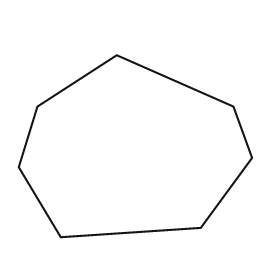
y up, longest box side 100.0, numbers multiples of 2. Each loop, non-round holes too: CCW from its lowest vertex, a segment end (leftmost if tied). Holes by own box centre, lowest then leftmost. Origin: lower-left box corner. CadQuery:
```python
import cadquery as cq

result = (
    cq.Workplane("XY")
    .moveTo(18.0, 0.0)
    .lineTo(78.0, 4.0)
    .lineTo(100.0, 34.0)
    .lineTo(92.0, 56.0)
    .lineTo(42.0, 78.0)
    .lineTo(8.0, 56.0)
    .lineTo(0.0, 30.0)
    .close()
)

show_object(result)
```